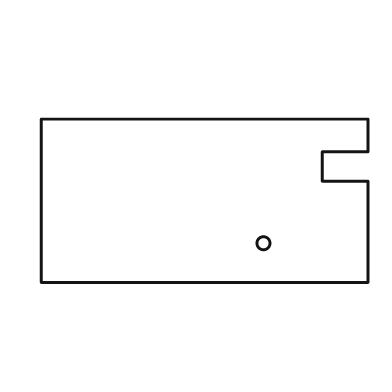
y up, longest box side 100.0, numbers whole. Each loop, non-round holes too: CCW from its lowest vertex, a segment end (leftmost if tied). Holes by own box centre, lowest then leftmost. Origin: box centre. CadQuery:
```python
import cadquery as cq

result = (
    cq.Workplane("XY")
    .moveTo(-50.0, -25.0)
    .lineTo(50.0, -25.0)
    .lineTo(50.0, 6.0)
    .lineTo(36.0, 6.0)
    .lineTo(36.0, 15.0)
    .lineTo(50.0, 15.0)
    .lineTo(50.0, 25.0)
    .lineTo(-50.0, 25.0)
    .close()
    .moveTo(18.0, -13.0)
    .circle(2.0)
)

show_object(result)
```